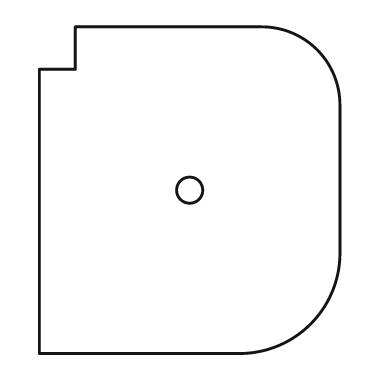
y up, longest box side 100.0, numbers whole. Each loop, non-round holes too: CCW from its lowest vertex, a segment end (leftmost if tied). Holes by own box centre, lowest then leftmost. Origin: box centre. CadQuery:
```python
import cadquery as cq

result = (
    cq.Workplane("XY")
    .moveTo(-46.0, -50.0)
    .lineTo(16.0, -50.0)
    .threePointArc((37.0, -41.0), (46.0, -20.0))
    .lineTo(46.0, 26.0)
    .threePointArc((39.0, 43.0), (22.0, 50.0))
    .lineTo(-35.0, 50.0)
    .lineTo(-35.0, 37.0)
    .lineTo(-46.0, 37.0)
    .close()
    .moveTo(0.0, 0.0)
    .circle(4.0)
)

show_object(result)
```